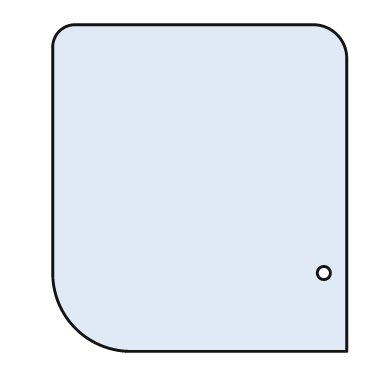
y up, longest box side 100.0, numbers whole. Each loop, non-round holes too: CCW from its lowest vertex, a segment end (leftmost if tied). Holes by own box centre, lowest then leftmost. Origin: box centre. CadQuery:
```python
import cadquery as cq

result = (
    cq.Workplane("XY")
    .moveTo(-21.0, -50.0)
    .lineTo(45.0, -50.0)
    .lineTo(45.0, 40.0)
    .threePointArc((42.0, 47.0), (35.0, 50.0))
    .lineTo(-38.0, 50.0)
    .threePointArc((-43.0, 48.0), (-45.0, 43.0))
    .lineTo(-45.0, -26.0)
    .threePointArc((-38.0, -43.0), (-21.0, -50.0))
    .close()
    .moveTo(38.0, -26.0)
    .circle(2.0)
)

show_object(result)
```